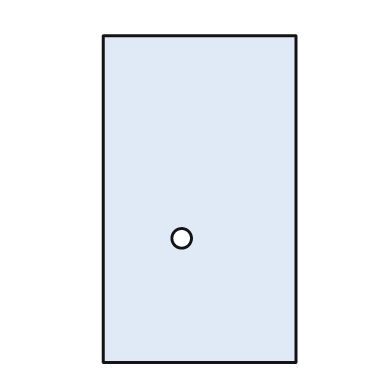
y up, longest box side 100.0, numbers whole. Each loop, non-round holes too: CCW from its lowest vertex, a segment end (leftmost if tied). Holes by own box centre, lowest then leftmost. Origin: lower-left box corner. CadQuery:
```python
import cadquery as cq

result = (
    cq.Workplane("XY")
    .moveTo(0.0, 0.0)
    .lineTo(59.0, 0.0)
    .lineTo(59.0, 100.0)
    .lineTo(0.0, 100.0)
    .close()
    .moveTo(24.0, 38.0)
    .circle(3.0)
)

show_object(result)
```